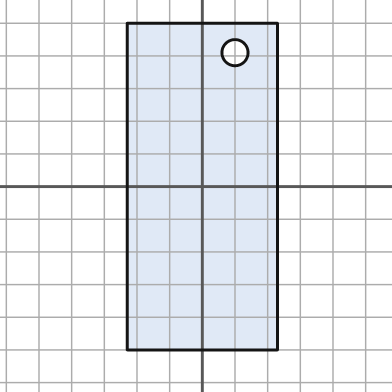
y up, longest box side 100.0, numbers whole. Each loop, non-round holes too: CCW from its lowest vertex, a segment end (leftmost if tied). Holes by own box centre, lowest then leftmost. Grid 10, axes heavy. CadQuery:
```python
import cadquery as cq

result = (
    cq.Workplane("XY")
    .moveTo(-23.0, -50.0)
    .lineTo(23.0, -50.0)
    .lineTo(23.0, 50.0)
    .lineTo(-23.0, 50.0)
    .close()
    .moveTo(10.0, 41.0)
    .circle(4.0)
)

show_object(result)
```